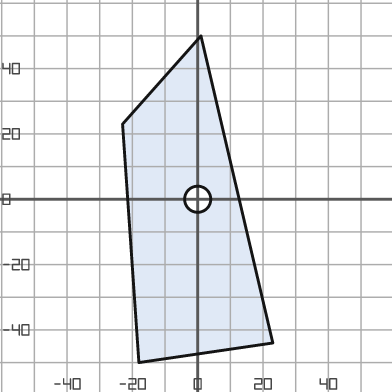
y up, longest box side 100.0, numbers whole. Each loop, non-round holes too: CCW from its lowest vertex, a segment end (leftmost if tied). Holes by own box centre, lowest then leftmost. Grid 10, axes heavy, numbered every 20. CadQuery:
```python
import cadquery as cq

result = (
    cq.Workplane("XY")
    .moveTo(-18.0, -50.0)
    .lineTo(23.0, -44.0)
    .lineTo(1.0, 50.0)
    .lineTo(-23.0, 23.0)
    .close()
    .moveTo(0.0, 0.0)
    .circle(4.0)
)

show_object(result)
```